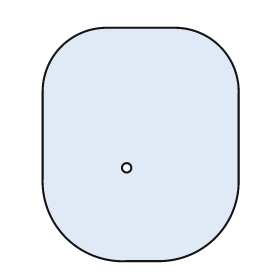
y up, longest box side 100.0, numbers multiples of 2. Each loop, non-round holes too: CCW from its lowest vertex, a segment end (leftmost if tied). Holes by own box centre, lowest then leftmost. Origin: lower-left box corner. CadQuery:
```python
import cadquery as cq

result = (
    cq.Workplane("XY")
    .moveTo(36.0, 0.0)
    .lineTo(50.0, 0.0)
    .threePointArc((74.0, 10.0), (84.0, 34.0))
    .lineTo(84.0, 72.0)
    .threePointArc((76.0, 92.0), (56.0, 100.0))
    .lineTo(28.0, 100.0)
    .threePointArc((8.0, 92.0), (0.0, 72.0))
    .lineTo(0.0, 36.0)
    .threePointArc((10.0, 10.0), (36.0, 0.0))
    .close()
    .moveTo(36.0, 40.0)
    .circle(2.0)
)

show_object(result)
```